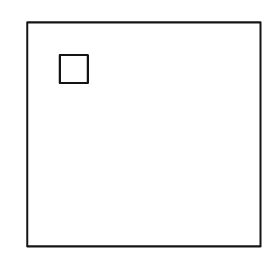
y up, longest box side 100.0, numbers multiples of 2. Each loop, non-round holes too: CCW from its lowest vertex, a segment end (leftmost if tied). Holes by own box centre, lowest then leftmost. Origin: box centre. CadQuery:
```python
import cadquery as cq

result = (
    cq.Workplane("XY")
    .moveTo(-50.0, -48.0)
    .lineTo(50.0, -48.0)
    .lineTo(50.0, 48.0)
    .lineTo(-50.0, 48.0)
    .close()
    .moveTo(-36.0, 22.0)
    .lineTo(-24.0, 22.0)
    .lineTo(-24.0, 34.0)
    .lineTo(-36.0, 34.0)
    .close()
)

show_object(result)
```